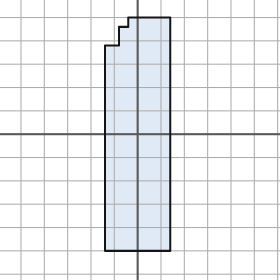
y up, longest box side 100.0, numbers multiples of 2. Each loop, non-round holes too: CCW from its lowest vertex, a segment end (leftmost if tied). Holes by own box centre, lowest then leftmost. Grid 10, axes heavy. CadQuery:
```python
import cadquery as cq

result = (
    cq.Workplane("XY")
    .moveTo(-14.0, -50.0)
    .lineTo(14.0, -50.0)
    .lineTo(14.0, 50.0)
    .lineTo(-4.0, 50.0)
    .lineTo(-4.0, 46.0)
    .lineTo(-8.0, 46.0)
    .lineTo(-8.0, 38.0)
    .lineTo(-14.0, 38.0)
    .close()
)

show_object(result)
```